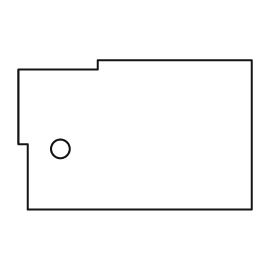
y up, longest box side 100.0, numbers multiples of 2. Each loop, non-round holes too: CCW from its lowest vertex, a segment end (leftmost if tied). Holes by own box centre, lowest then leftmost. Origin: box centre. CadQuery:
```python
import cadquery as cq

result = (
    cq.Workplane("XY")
    .moveTo(-46.0, -32.0)
    .lineTo(50.0, -32.0)
    .lineTo(50.0, 32.0)
    .lineTo(-16.0, 32.0)
    .lineTo(-16.0, 28.0)
    .lineTo(-50.0, 28.0)
    .lineTo(-50.0, -4.0)
    .lineTo(-46.0, -4.0)
    .close()
    .moveTo(-32.0, -6.0)
    .circle(4.0)
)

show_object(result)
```